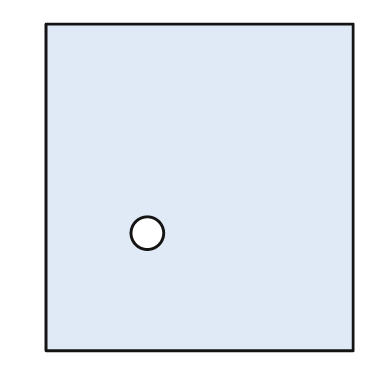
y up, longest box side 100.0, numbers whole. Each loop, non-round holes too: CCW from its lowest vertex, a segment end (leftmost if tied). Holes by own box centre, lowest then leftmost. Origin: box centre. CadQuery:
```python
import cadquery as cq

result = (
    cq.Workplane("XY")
    .moveTo(-47.0, -50.0)
    .lineTo(47.0, -50.0)
    .lineTo(47.0, 50.0)
    .lineTo(-47.0, 50.0)
    .close()
    .moveTo(-16.0, -14.0)
    .circle(5.0)
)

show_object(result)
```